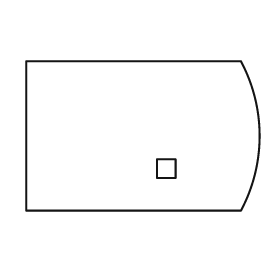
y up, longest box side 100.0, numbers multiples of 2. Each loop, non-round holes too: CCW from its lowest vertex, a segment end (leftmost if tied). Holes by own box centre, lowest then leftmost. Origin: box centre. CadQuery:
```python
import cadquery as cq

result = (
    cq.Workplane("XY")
    .moveTo(-50.0, -32.0)
    .lineTo(42.0, -32.0)
    .threePointArc((50.0, 0.0), (42.0, 32.0))
    .lineTo(-50.0, 32.0)
    .close()
    .moveTo(6.0, -18.0)
    .lineTo(14.0, -18.0)
    .lineTo(14.0, -10.0)
    .lineTo(6.0, -10.0)
    .close()
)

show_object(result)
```